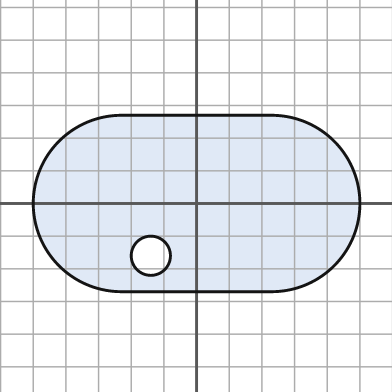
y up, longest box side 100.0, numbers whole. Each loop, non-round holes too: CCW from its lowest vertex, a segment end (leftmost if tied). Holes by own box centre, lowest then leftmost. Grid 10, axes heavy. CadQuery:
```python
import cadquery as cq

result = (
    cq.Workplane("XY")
    .moveTo(-23.0, -27.0)
    .lineTo(23.0, -27.0)
    .threePointArc((50.0, 0.0), (23.0, 27.0))
    .lineTo(-23.0, 27.0)
    .threePointArc((-50.0, 0.0), (-23.0, -27.0))
    .close()
    .moveTo(-14.0, -16.0)
    .circle(6.0)
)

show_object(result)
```